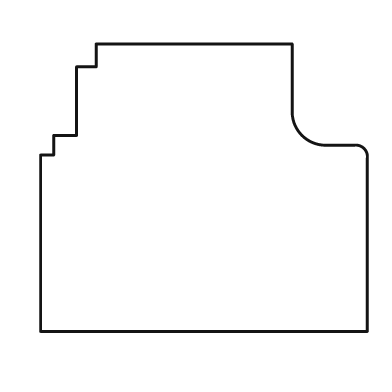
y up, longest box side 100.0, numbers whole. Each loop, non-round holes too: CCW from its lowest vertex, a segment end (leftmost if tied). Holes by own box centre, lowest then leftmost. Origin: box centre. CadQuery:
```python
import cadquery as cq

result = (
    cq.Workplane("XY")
    .moveTo(-50.0, -44.0)
    .lineTo(50.0, -44.0)
    .lineTo(50.0, 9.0)
    .threePointArc((49.0, 12.0), (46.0, 13.0))
    .lineTo(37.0, 13.0)
    .threePointArc((30.0, 16.0), (27.0, 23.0))
    .lineTo(27.0, 44.0)
    .lineTo(-33.0, 44.0)
    .lineTo(-33.0, 37.0)
    .lineTo(-39.0, 37.0)
    .lineTo(-39.0, 16.0)
    .lineTo(-46.0, 16.0)
    .lineTo(-46.0, 10.0)
    .lineTo(-50.0, 10.0)
    .close()
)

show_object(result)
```